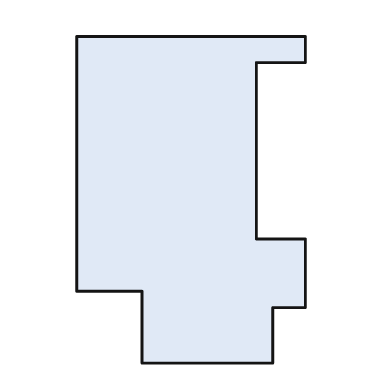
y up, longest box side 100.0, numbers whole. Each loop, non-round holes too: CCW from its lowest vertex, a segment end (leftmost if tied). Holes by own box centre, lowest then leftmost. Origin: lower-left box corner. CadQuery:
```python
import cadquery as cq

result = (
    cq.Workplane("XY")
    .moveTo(20.0, 0.0)
    .lineTo(60.0, 0.0)
    .lineTo(60.0, 17.0)
    .lineTo(70.0, 17.0)
    .lineTo(70.0, 38.0)
    .lineTo(55.0, 38.0)
    .lineTo(55.0, 92.0)
    .lineTo(70.0, 92.0)
    .lineTo(70.0, 100.0)
    .lineTo(0.0, 100.0)
    .lineTo(0.0, 22.0)
    .lineTo(20.0, 22.0)
    .close()
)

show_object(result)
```